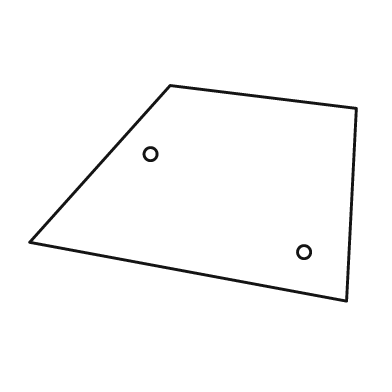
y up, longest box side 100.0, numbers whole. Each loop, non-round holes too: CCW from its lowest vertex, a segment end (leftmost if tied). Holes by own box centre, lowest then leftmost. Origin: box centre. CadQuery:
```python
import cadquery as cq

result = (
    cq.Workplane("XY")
    .moveTo(47.0, -33.0)
    .lineTo(50.0, 26.0)
    .lineTo(-7.0, 33.0)
    .lineTo(-50.0, -15.0)
    .close()
    .moveTo(34.0, -18.0)
    .circle(2.0)
    .moveTo(-13.0, 12.0)
    .circle(2.0)
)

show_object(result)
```